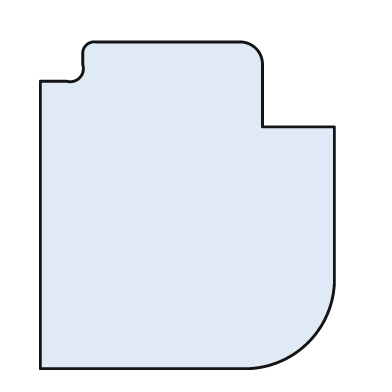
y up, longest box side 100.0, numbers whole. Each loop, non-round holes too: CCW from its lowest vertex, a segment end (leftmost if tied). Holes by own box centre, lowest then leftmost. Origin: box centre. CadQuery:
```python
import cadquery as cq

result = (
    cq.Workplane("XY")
    .moveTo(-45.0, -50.0)
    .lineTo(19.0, -50.0)
    .threePointArc((37.0, -42.0), (45.0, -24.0))
    .lineTo(45.0, 24.0)
    .lineTo(23.0, 24.0)
    .lineTo(23.0, 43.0)
    .threePointArc((21.0, 48.0), (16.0, 50.0))
    .lineTo(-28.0, 50.0)
    .threePointArc((-31.0, 49.0), (-32.0, 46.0))
    .lineTo(-32.0, 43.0)
    .threePointArc((-33.0, 39.0), (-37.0, 38.0))
    .lineTo(-45.0, 38.0)
    .close()
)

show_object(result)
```